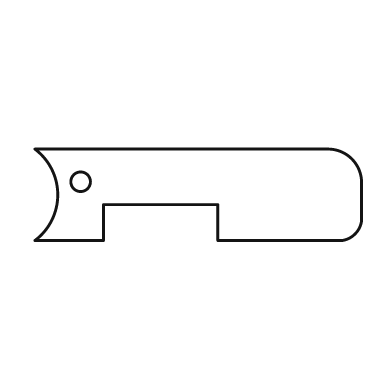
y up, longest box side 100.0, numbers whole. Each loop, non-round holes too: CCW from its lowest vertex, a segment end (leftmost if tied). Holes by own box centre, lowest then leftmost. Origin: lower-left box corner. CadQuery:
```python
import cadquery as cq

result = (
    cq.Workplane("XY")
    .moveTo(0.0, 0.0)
    .lineTo(21.0, 0.0)
    .lineTo(21.0, 11.0)
    .lineTo(56.0, 11.0)
    .lineTo(56.0, 0.0)
    .lineTo(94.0, 0.0)
    .threePointArc((98.0, 2.0), (100.0, 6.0))
    .lineTo(100.0, 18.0)
    .threePointArc((97.0, 25.0), (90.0, 28.0))
    .lineTo(0.0, 28.0)
    .threePointArc((7.0, 14.0), (0.0, 0.0))
    .close()
    .moveTo(14.0, 18.0)
    .circle(3.0)
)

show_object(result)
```